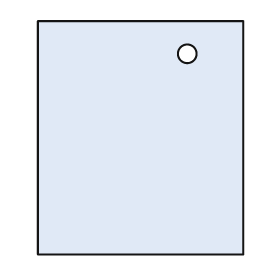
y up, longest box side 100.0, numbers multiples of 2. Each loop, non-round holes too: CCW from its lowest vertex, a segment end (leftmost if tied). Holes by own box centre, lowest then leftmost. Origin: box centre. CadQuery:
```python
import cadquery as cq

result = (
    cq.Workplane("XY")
    .moveTo(-44.0, -50.0)
    .lineTo(44.0, -50.0)
    .lineTo(44.0, 50.0)
    .lineTo(-44.0, 50.0)
    .close()
    .moveTo(20.0, 36.0)
    .circle(4.0)
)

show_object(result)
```